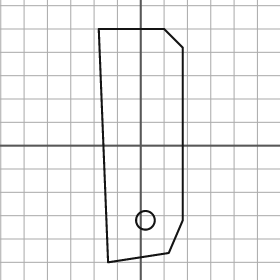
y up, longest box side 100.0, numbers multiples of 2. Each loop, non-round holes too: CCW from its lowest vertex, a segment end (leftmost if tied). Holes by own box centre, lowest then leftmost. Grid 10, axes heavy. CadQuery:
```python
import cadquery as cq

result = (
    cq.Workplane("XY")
    .moveTo(-14.0, -50.0)
    .lineTo(12.0, -46.0)
    .lineTo(18.0, -32.0)
    .lineTo(18.0, 42.0)
    .lineTo(10.0, 50.0)
    .lineTo(-18.0, 50.0)
    .close()
    .moveTo(2.0, -32.0)
    .circle(4.0)
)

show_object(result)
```